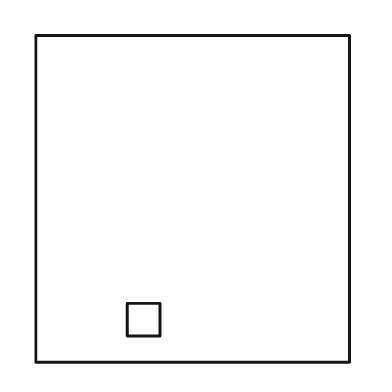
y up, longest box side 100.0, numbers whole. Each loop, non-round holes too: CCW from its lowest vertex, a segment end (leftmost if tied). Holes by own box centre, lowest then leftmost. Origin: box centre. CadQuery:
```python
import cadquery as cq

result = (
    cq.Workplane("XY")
    .moveTo(-48.0, -50.0)
    .lineTo(48.0, -50.0)
    .lineTo(48.0, 50.0)
    .lineTo(-48.0, 50.0)
    .close()
    .moveTo(-20.0, -42.0)
    .lineTo(-10.0, -42.0)
    .lineTo(-10.0, -32.0)
    .lineTo(-20.0, -32.0)
    .close()
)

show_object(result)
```